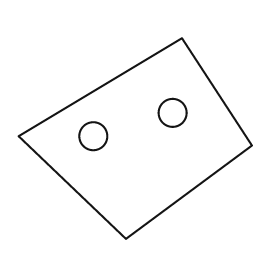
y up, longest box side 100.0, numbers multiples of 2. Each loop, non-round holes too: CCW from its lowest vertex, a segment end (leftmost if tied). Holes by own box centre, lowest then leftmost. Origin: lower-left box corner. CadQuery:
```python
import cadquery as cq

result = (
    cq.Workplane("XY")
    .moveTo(46.0, 0.0)
    .lineTo(100.0, 40.0)
    .lineTo(70.0, 86.0)
    .lineTo(0.0, 44.0)
    .close()
    .moveTo(32.0, 44.0)
    .circle(6.0)
    .moveTo(66.0, 54.0)
    .circle(6.0)
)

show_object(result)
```